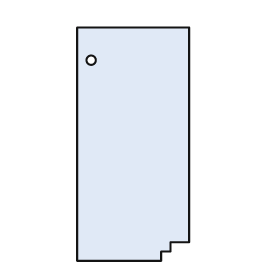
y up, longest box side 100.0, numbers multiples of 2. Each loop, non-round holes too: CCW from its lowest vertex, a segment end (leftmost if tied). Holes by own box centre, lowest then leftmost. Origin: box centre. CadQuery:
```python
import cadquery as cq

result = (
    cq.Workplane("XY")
    .moveTo(-24.0, -50.0)
    .lineTo(12.0, -50.0)
    .lineTo(12.0, -46.0)
    .lineTo(16.0, -46.0)
    .lineTo(16.0, -42.0)
    .lineTo(24.0, -42.0)
    .lineTo(24.0, 50.0)
    .lineTo(-24.0, 50.0)
    .close()
    .moveTo(-18.0, 36.0)
    .circle(2.0)
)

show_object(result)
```